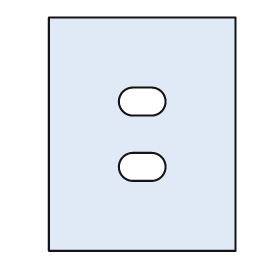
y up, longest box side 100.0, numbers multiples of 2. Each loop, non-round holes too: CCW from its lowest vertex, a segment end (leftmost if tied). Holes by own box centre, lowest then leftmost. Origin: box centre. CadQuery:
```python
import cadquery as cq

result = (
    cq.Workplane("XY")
    .moveTo(-40.0, -50.0)
    .lineTo(40.0, -50.0)
    .lineTo(40.0, 50.0)
    .lineTo(-40.0, 50.0)
    .close()
    .moveTo(-4.0, -20.0)
    .lineTo(4.0, -20.0)
    .threePointArc((10.0, -14.0), (4.0, -8.0))
    .lineTo(-4.0, -8.0)
    .threePointArc((-10.0, -14.0), (-4.0, -20.0))
    .close()
    .moveTo(-4.0, 8.0)
    .lineTo(4.0, 8.0)
    .threePointArc((10.0, 14.0), (4.0, 20.0))
    .lineTo(-4.0, 20.0)
    .threePointArc((-10.0, 14.0), (-4.0, 8.0))
    .close()
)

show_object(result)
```